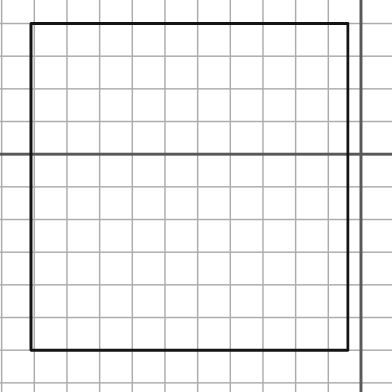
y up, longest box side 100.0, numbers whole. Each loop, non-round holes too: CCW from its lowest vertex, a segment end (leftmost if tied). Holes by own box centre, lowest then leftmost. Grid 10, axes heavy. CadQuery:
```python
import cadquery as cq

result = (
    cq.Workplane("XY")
    .moveTo(-101.0, -60.0)
    .lineTo(-4.0, -60.0)
    .lineTo(-4.0, 40.0)
    .lineTo(-101.0, 40.0)
    .close()
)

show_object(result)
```